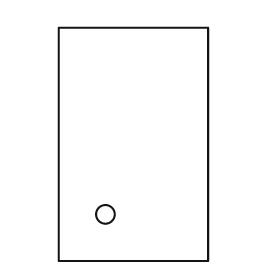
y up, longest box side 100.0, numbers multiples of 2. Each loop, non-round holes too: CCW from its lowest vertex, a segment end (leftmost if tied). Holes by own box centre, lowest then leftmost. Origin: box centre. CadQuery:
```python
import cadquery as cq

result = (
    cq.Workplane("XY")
    .moveTo(-32.0, -50.0)
    .lineTo(32.0, -50.0)
    .lineTo(32.0, 50.0)
    .lineTo(-32.0, 50.0)
    .close()
    .moveTo(-12.0, -30.0)
    .circle(4.0)
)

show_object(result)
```